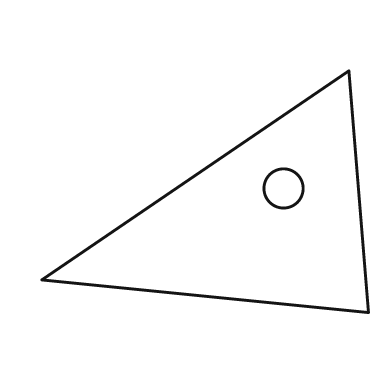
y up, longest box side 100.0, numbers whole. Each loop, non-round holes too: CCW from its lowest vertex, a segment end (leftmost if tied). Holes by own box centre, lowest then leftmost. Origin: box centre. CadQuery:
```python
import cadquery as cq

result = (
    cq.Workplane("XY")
    .moveTo(50.0, -37.0)
    .lineTo(44.0, 37.0)
    .lineTo(-50.0, -27.0)
    .close()
    .moveTo(24.0, 1.0)
    .circle(6.0)
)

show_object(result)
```